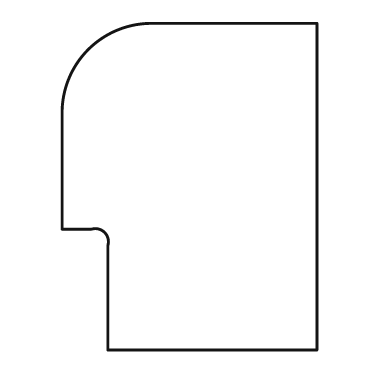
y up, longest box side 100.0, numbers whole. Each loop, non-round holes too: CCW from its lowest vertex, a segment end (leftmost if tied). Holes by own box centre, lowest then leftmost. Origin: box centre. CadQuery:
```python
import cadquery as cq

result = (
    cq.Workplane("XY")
    .moveTo(-25.0, -50.0)
    .lineTo(39.0, -50.0)
    .lineTo(39.0, 50.0)
    .lineTo(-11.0, 50.0)
    .threePointArc((-31.0, 42.0), (-39.0, 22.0))
    .lineTo(-39.0, -13.0)
    .lineTo(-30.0, -13.0)
    .threePointArc((-26.0, -14.0), (-25.0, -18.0))
    .close()
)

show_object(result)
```